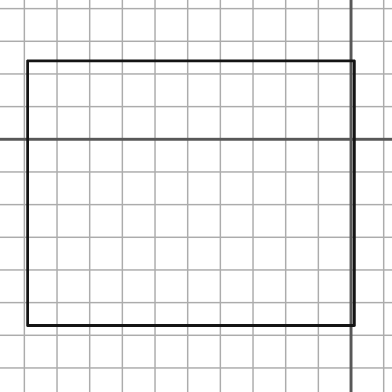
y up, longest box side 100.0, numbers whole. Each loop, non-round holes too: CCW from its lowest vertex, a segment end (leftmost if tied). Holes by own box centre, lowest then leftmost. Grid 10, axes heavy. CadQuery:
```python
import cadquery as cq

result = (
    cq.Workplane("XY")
    .moveTo(-99.0, -57.0)
    .lineTo(1.0, -57.0)
    .lineTo(1.0, 24.0)
    .lineTo(-99.0, 24.0)
    .close()
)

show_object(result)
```